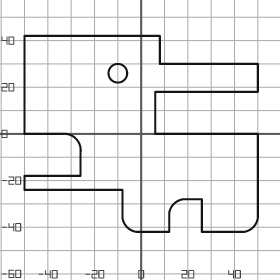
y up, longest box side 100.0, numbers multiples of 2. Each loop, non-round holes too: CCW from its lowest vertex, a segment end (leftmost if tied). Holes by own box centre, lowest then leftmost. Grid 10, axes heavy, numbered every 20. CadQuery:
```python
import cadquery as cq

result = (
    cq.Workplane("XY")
    .moveTo(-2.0, -42.0)
    .lineTo(12.0, -42.0)
    .lineTo(12.0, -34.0)
    .threePointArc((14.0, -30.0), (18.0, -28.0))
    .lineTo(26.0, -28.0)
    .lineTo(26.0, -42.0)
    .lineTo(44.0, -42.0)
    .threePointArc((48.0, -40.0), (50.0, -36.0))
    .lineTo(50.0, 0.0)
    .lineTo(6.0, 0.0)
    .lineTo(6.0, 18.0)
    .lineTo(50.0, 18.0)
    .lineTo(50.0, 30.0)
    .lineTo(8.0, 30.0)
    .lineTo(8.0, 42.0)
    .lineTo(-50.0, 42.0)
    .lineTo(-50.0, 0.0)
    .lineTo(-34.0, 0.0)
    .threePointArc((-28.0, -2.0), (-26.0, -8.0))
    .lineTo(-26.0, -18.0)
    .lineTo(-50.0, -18.0)
    .lineTo(-50.0, -24.0)
    .lineTo(-8.0, -24.0)
    .lineTo(-8.0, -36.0)
    .threePointArc((-6.0, -40.0), (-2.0, -42.0))
    .close()
    .moveTo(-10.0, 26.0)
    .circle(4.0)
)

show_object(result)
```